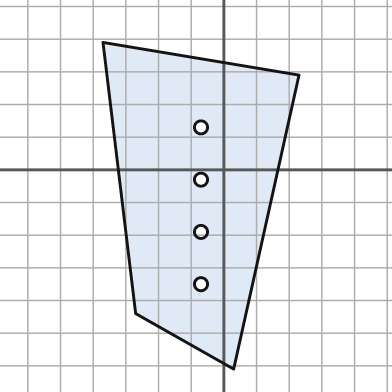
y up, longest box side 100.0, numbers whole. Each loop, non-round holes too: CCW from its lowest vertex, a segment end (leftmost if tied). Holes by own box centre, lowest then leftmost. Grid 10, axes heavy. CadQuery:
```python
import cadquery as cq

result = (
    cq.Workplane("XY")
    .moveTo(3.0, -61.0)
    .lineTo(23.0, 29.0)
    .lineTo(-37.0, 39.0)
    .lineTo(-27.0, -44.0)
    .close()
    .moveTo(-7.0, -35.0)
    .circle(2.0)
    .moveTo(-7.0, -19.0)
    .circle(2.0)
    .moveTo(-7.0, -3.0)
    .circle(2.0)
    .moveTo(-7.0, 13.0)
    .circle(2.0)
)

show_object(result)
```